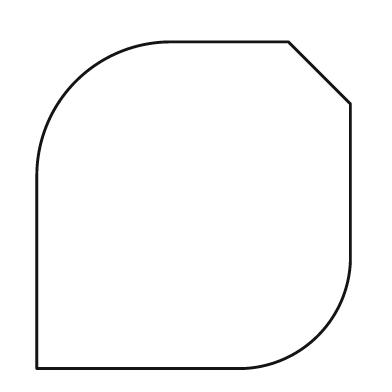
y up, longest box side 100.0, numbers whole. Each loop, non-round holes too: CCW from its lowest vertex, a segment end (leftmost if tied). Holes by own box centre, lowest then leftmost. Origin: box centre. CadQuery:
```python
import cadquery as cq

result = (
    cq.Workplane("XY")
    .moveTo(-48.0, -50.0)
    .lineTo(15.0, -50.0)
    .threePointArc((38.0, -40.0), (48.0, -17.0))
    .lineTo(48.0, 31.0)
    .lineTo(29.0, 50.0)
    .lineTo(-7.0, 50.0)
    .threePointArc((-36.0, 38.0), (-48.0, 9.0))
    .close()
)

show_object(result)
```